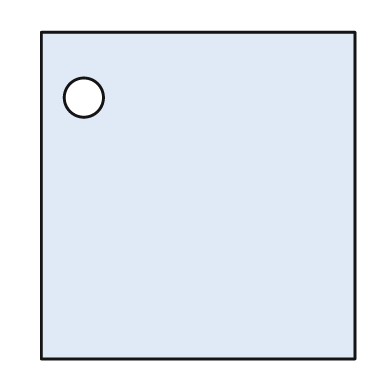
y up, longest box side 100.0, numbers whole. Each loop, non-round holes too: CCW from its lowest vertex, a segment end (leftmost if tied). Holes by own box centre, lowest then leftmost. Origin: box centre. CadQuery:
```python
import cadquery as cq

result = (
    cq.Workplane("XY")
    .moveTo(-48.0, -50.0)
    .lineTo(48.0, -50.0)
    .lineTo(48.0, 50.0)
    .lineTo(-48.0, 50.0)
    .close()
    .moveTo(-35.0, 30.0)
    .circle(6.0)
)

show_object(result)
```